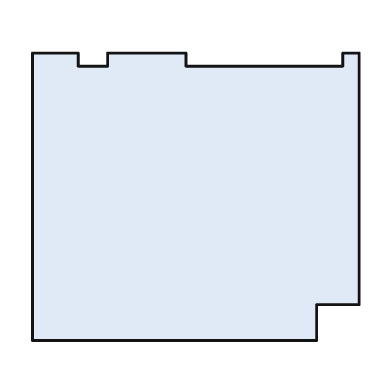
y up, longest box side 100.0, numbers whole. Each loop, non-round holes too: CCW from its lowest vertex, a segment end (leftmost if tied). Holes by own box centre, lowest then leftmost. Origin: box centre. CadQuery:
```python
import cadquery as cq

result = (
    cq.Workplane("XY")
    .moveTo(-50.0, -44.0)
    .lineTo(37.0, -44.0)
    .lineTo(37.0, -33.0)
    .lineTo(50.0, -33.0)
    .lineTo(50.0, 44.0)
    .lineTo(45.0, 44.0)
    .lineTo(45.0, 40.0)
    .lineTo(-3.0, 40.0)
    .lineTo(-3.0, 44.0)
    .lineTo(-27.0, 44.0)
    .lineTo(-27.0, 40.0)
    .lineTo(-36.0, 40.0)
    .lineTo(-36.0, 44.0)
    .lineTo(-50.0, 44.0)
    .close()
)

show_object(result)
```